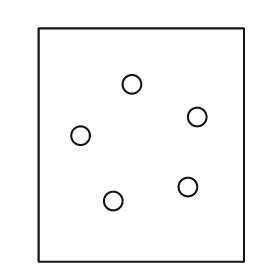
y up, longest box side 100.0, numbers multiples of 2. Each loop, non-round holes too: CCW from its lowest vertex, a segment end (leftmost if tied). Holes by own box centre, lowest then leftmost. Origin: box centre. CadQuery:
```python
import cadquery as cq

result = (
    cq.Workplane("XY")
    .moveTo(-44.0, -50.0)
    .lineTo(44.0, -50.0)
    .lineTo(44.0, 50.0)
    .lineTo(-44.0, 50.0)
    .close()
    .moveTo(-12.0, -24.0)
    .circle(4.0)
    .moveTo(20.0, -18.0)
    .circle(4.0)
    .moveTo(-26.0, 4.0)
    .circle(4.0)
    .moveTo(24.0, 12.0)
    .circle(4.0)
    .moveTo(-4.0, 26.0)
    .circle(4.0)
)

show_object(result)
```